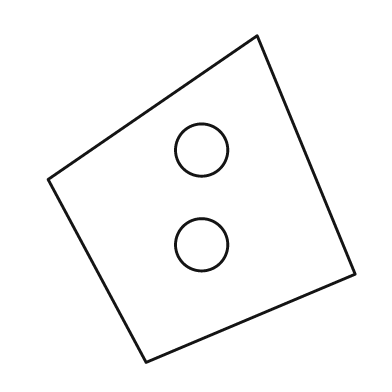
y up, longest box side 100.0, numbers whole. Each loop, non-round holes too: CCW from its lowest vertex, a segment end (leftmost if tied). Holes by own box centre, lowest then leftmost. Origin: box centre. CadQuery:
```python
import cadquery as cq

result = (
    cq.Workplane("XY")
    .moveTo(-17.0, -50.0)
    .lineTo(47.0, -23.0)
    .lineTo(17.0, 50.0)
    .lineTo(-47.0, 6.0)
    .close()
    .moveTo(0.0, -14.0)
    .circle(8.0)
    .moveTo(0.0, 15.0)
    .circle(8.0)
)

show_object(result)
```